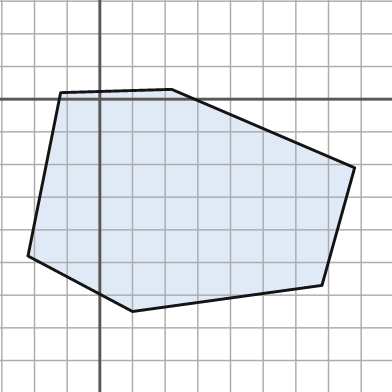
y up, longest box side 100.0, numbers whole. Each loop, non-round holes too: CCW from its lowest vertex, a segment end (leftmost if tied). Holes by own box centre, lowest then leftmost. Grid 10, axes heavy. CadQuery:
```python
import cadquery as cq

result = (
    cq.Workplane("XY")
    .moveTo(10.0, -65.0)
    .lineTo(68.0, -57.0)
    .lineTo(78.0, -21.0)
    .lineTo(22.0, 3.0)
    .lineTo(-12.0, 2.0)
    .lineTo(-22.0, -48.0)
    .close()
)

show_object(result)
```